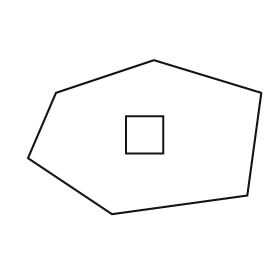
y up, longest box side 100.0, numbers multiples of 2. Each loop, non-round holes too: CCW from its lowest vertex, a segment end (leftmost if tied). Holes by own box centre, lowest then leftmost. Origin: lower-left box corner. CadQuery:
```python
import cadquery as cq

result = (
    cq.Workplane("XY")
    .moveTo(36.0, 0.0)
    .lineTo(94.0, 8.0)
    .lineTo(100.0, 52.0)
    .lineTo(54.0, 66.0)
    .lineTo(12.0, 52.0)
    .lineTo(0.0, 24.0)
    .close()
    .moveTo(42.0, 26.0)
    .lineTo(58.0, 26.0)
    .lineTo(58.0, 42.0)
    .lineTo(42.0, 42.0)
    .close()
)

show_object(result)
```